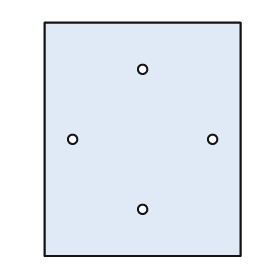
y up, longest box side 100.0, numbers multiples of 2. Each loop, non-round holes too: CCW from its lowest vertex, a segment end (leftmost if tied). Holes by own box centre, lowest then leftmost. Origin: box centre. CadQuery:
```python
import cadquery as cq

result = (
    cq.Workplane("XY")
    .moveTo(-42.0, -50.0)
    .lineTo(42.0, -50.0)
    .lineTo(42.0, 50.0)
    .lineTo(-42.0, 50.0)
    .close()
    .moveTo(0.0, -30.0)
    .circle(2.0)
    .moveTo(-30.0, 0.0)
    .circle(2.0)
    .moveTo(30.0, 0.0)
    .circle(2.0)
    .moveTo(0.0, 30.0)
    .circle(2.0)
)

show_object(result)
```